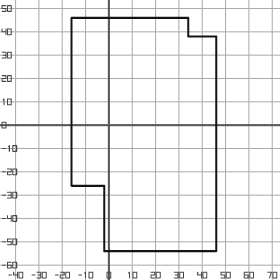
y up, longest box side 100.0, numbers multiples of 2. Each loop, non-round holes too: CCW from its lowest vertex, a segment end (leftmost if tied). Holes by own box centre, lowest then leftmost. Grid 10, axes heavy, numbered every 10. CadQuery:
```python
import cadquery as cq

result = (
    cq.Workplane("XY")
    .moveTo(-2.0, -54.0)
    .lineTo(46.0, -54.0)
    .lineTo(46.0, 38.0)
    .lineTo(34.0, 38.0)
    .lineTo(34.0, 46.0)
    .lineTo(-16.0, 46.0)
    .lineTo(-16.0, -26.0)
    .lineTo(-2.0, -26.0)
    .close()
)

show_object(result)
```